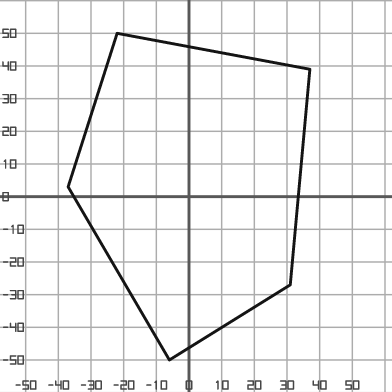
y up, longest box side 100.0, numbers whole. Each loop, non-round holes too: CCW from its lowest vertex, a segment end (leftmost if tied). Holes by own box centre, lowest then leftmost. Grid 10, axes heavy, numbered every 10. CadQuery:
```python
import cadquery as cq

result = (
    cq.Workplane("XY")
    .moveTo(-6.0, -50.0)
    .lineTo(31.0, -27.0)
    .lineTo(37.0, 39.0)
    .lineTo(-22.0, 50.0)
    .lineTo(-37.0, 3.0)
    .close()
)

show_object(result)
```